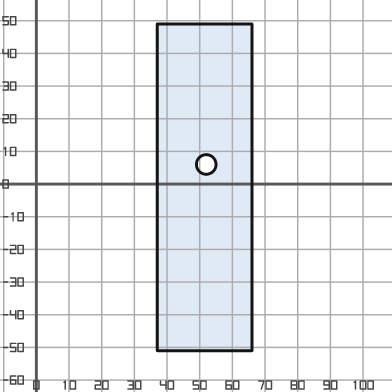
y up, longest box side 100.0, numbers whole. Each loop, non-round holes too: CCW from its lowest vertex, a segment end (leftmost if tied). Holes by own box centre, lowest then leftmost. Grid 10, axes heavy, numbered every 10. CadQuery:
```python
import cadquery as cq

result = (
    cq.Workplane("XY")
    .moveTo(37.0, -51.0)
    .lineTo(66.0, -51.0)
    .lineTo(66.0, 49.0)
    .lineTo(37.0, 49.0)
    .close()
    .moveTo(52.0, 6.0)
    .circle(3.0)
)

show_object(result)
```